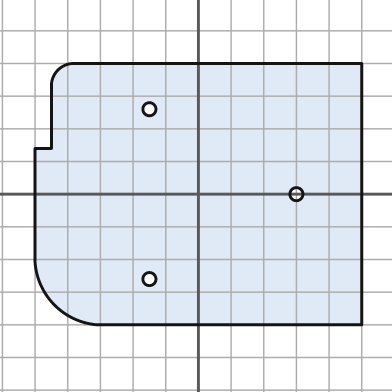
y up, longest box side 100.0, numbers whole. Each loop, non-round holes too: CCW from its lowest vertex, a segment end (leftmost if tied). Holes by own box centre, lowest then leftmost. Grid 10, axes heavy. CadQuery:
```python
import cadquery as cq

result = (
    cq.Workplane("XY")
    .moveTo(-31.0, -40.0)
    .lineTo(50.0, -40.0)
    .lineTo(50.0, 40.0)
    .lineTo(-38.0, 40.0)
    .threePointArc((-43.0, 38.0), (-45.0, 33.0))
    .lineTo(-45.0, 14.0)
    .lineTo(-50.0, 14.0)
    .lineTo(-50.0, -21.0)
    .threePointArc((-44.0, -34.0), (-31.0, -40.0))
    .close()
    .moveTo(-15.0, -26.0)
    .circle(2.0)
    .moveTo(30.0, 0.0)
    .circle(2.0)
    .moveTo(-15.0, 26.0)
    .circle(2.0)
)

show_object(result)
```